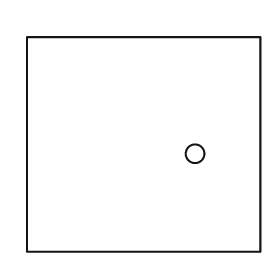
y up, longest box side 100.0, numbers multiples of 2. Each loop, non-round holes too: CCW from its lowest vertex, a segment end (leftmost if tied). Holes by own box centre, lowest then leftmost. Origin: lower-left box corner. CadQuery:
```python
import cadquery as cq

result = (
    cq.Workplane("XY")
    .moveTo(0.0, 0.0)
    .lineTo(100.0, 0.0)
    .lineTo(100.0, 92.0)
    .lineTo(0.0, 92.0)
    .close()
    .moveTo(72.0, 42.0)
    .circle(4.0)
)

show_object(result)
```